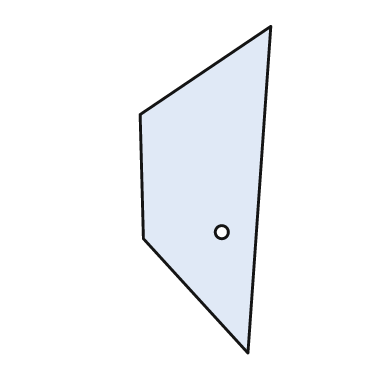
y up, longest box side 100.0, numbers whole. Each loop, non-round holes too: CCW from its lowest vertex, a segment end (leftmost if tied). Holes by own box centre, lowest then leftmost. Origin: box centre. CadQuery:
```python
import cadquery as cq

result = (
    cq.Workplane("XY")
    .moveTo(13.0, -50.0)
    .lineTo(20.0, 50.0)
    .lineTo(-20.0, 23.0)
    .lineTo(-19.0, -15.0)
    .close()
    .moveTo(5.0, -13.0)
    .circle(2.0)
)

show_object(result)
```